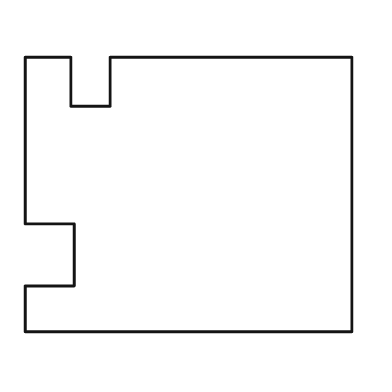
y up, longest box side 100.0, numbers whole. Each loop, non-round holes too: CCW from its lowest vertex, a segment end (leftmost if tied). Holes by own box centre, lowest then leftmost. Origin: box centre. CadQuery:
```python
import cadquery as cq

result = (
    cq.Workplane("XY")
    .moveTo(-50.0, -42.0)
    .lineTo(50.0, -42.0)
    .lineTo(50.0, 42.0)
    .lineTo(-24.0, 42.0)
    .lineTo(-24.0, 27.0)
    .lineTo(-36.0, 27.0)
    .lineTo(-36.0, 42.0)
    .lineTo(-50.0, 42.0)
    .lineTo(-50.0, -9.0)
    .lineTo(-35.0, -9.0)
    .lineTo(-35.0, -28.0)
    .lineTo(-50.0, -28.0)
    .close()
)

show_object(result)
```